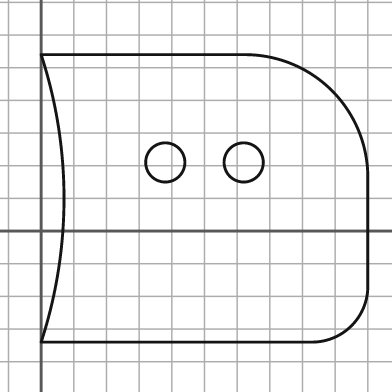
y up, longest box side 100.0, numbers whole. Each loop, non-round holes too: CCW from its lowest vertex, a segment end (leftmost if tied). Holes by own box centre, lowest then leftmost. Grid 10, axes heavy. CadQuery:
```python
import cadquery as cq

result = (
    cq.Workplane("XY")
    .moveTo(0.0, -34.0)
    .lineTo(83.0, -34.0)
    .threePointArc((95.0, -29.0), (100.0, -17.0))
    .lineTo(100.0, 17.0)
    .threePointArc((89.0, 43.0), (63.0, 54.0))
    .lineTo(0.0, 54.0)
    .threePointArc((7.0, 10.0), (0.0, -34.0))
    .close()
    .moveTo(38.0, 21.0)
    .circle(6.0)
    .moveTo(62.0, 21.0)
    .circle(6.0)
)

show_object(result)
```